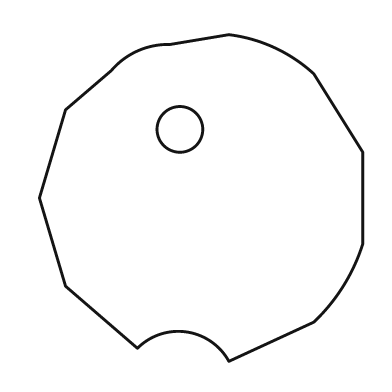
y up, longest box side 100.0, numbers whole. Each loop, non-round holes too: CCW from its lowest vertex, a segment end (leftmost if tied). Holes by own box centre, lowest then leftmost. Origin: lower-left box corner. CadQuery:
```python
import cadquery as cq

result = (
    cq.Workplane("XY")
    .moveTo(58.0, 0.0)
    .lineTo(84.0, 12.0)
    .threePointArc((93.0, 23.0), (99.0, 36.0))
    .lineTo(99.0, 64.0)
    .lineTo(84.0, 88.0)
    .threePointArc((72.0, 96.0), (58.0, 100.0))
    .lineTo(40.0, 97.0)
    .threePointArc((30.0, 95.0), (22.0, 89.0))
    .lineTo(8.0, 77.0)
    .lineTo(0.0, 50.0)
    .lineTo(8.0, 23.0)
    .lineTo(30.0, 4.0)
    .threePointArc((45.0, 9.0), (58.0, 0.0))
    .close()
    .moveTo(43.0, 71.0)
    .circle(7.0)
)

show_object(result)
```